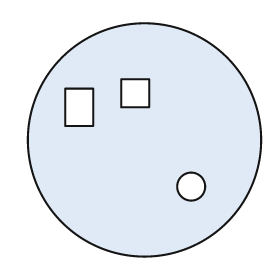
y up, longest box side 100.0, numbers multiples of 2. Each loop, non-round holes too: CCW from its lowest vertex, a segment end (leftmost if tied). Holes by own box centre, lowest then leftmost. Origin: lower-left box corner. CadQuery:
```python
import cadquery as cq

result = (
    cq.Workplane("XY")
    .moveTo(50.0, 50.0)
    .circle(50.0)
    .moveTo(70.0, 30.0)
    .circle(6.0)
    .moveTo(16.0, 56.0)
    .lineTo(28.0, 56.0)
    .lineTo(28.0, 72.0)
    .lineTo(16.0, 72.0)
    .close()
    .moveTo(40.0, 64.0)
    .lineTo(52.0, 64.0)
    .lineTo(52.0, 76.0)
    .lineTo(40.0, 76.0)
    .close()
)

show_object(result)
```